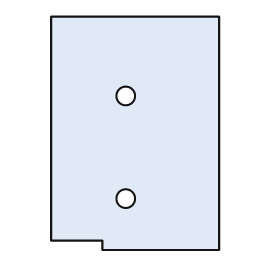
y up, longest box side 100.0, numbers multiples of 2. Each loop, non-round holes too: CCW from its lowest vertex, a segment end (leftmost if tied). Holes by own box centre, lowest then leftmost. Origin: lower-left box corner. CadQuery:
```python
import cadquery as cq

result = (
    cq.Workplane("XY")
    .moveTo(22.0, 0.0)
    .lineTo(72.0, 0.0)
    .lineTo(72.0, 100.0)
    .lineTo(0.0, 100.0)
    .lineTo(0.0, 4.0)
    .lineTo(22.0, 4.0)
    .close()
    .moveTo(32.0, 22.0)
    .circle(4.0)
    .moveTo(32.0, 66.0)
    .circle(4.0)
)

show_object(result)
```